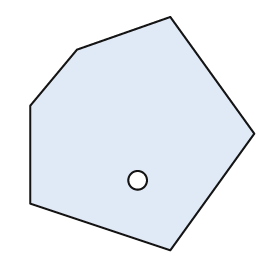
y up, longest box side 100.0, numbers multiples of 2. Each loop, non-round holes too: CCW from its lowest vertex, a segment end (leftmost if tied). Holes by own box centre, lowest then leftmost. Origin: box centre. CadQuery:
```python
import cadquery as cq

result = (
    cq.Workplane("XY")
    .moveTo(12.0, -50.0)
    .lineTo(48.0, 0.0)
    .lineTo(12.0, 50.0)
    .lineTo(-28.0, 36.0)
    .lineTo(-48.0, 12.0)
    .lineTo(-48.0, -30.0)
    .close()
    .moveTo(-2.0, -20.0)
    .circle(4.0)
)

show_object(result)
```